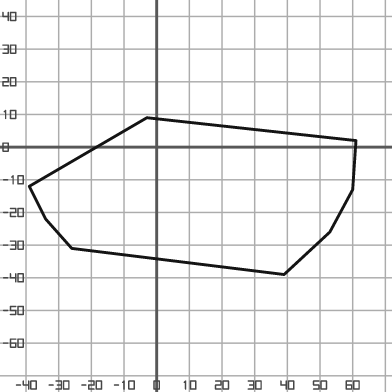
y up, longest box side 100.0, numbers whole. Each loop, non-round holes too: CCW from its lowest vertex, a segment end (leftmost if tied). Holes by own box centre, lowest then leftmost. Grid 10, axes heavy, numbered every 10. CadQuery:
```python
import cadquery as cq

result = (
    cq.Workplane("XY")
    .moveTo(39.0, -39.0)
    .lineTo(53.0, -26.0)
    .lineTo(60.0, -13.0)
    .lineTo(61.0, 2.0)
    .lineTo(-3.0, 9.0)
    .lineTo(-39.0, -12.0)
    .lineTo(-34.0, -22.0)
    .lineTo(-26.0, -31.0)
    .close()
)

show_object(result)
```